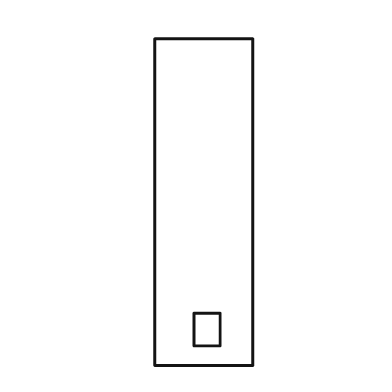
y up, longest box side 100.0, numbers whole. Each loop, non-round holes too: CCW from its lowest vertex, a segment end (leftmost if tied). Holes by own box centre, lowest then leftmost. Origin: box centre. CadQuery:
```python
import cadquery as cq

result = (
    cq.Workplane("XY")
    .moveTo(-15.0, -50.0)
    .lineTo(15.0, -50.0)
    .lineTo(15.0, 50.0)
    .lineTo(-15.0, 50.0)
    .close()
    .moveTo(-3.0, -44.0)
    .lineTo(5.0, -44.0)
    .lineTo(5.0, -34.0)
    .lineTo(-3.0, -34.0)
    .close()
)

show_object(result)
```